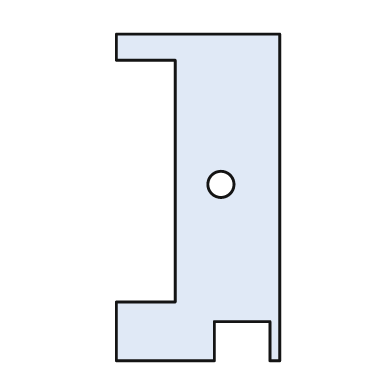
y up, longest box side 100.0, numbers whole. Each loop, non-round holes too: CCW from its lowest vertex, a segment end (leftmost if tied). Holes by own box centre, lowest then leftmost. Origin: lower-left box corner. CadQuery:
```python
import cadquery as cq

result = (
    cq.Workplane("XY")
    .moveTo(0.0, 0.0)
    .lineTo(30.0, 0.0)
    .lineTo(30.0, 12.0)
    .lineTo(47.0, 12.0)
    .lineTo(47.0, 0.0)
    .lineTo(50.0, 0.0)
    .lineTo(50.0, 100.0)
    .lineTo(0.0, 100.0)
    .lineTo(0.0, 92.0)
    .lineTo(18.0, 92.0)
    .lineTo(18.0, 18.0)
    .lineTo(0.0, 18.0)
    .close()
    .moveTo(32.0, 54.0)
    .circle(4.0)
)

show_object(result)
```